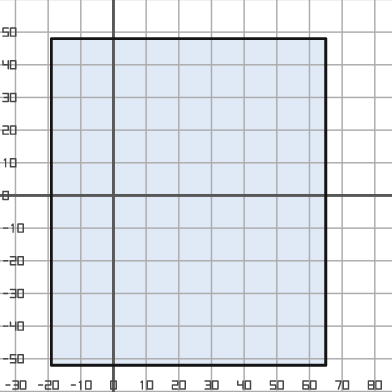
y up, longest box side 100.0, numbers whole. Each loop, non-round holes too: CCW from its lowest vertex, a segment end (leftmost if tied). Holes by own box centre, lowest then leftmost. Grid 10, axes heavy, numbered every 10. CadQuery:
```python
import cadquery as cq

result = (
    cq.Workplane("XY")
    .moveTo(-19.0, -52.0)
    .lineTo(65.0, -52.0)
    .lineTo(65.0, 48.0)
    .lineTo(-19.0, 48.0)
    .close()
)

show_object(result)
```